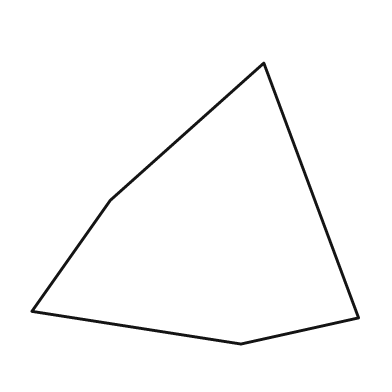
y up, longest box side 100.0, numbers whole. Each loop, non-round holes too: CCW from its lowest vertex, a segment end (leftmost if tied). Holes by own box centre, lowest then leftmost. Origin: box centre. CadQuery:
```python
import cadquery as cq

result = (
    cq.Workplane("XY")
    .moveTo(14.0, -43.0)
    .lineTo(50.0, -35.0)
    .lineTo(21.0, 43.0)
    .lineTo(-26.0, 1.0)
    .lineTo(-50.0, -33.0)
    .close()
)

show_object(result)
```